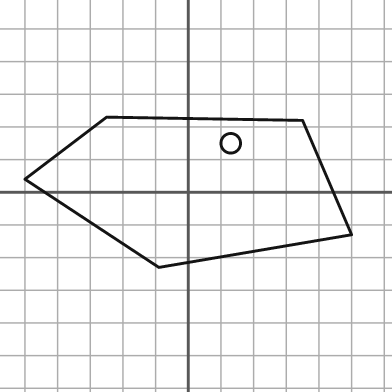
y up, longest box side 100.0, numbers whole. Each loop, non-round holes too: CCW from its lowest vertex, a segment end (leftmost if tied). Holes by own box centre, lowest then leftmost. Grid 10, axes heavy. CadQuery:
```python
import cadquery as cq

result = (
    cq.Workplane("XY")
    .moveTo(-9.0, -23.0)
    .lineTo(50.0, -13.0)
    .lineTo(35.0, 22.0)
    .lineTo(-25.0, 23.0)
    .lineTo(-50.0, 4.0)
    .close()
    .moveTo(13.0, 15.0)
    .circle(3.0)
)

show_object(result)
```